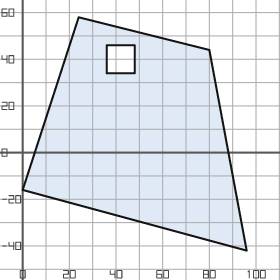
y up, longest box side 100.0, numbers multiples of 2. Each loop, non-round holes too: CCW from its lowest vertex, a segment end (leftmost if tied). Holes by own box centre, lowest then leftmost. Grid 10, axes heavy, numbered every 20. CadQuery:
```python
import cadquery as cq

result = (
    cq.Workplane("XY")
    .moveTo(96.0, -42.0)
    .lineTo(80.0, 44.0)
    .lineTo(24.0, 58.0)
    .lineTo(0.0, -16.0)
    .close()
    .moveTo(36.0, 34.0)
    .lineTo(48.0, 34.0)
    .lineTo(48.0, 46.0)
    .lineTo(36.0, 46.0)
    .close()
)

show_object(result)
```